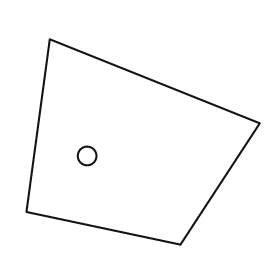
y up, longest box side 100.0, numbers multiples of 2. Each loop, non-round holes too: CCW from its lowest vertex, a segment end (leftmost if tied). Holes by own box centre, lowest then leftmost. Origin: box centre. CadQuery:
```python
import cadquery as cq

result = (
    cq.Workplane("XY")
    .moveTo(16.0, -44.0)
    .lineTo(50.0, 8.0)
    .lineTo(-40.0, 44.0)
    .lineTo(-50.0, -30.0)
    .close()
    .moveTo(-24.0, -6.0)
    .circle(4.0)
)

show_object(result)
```